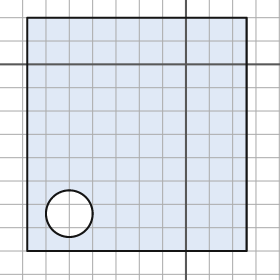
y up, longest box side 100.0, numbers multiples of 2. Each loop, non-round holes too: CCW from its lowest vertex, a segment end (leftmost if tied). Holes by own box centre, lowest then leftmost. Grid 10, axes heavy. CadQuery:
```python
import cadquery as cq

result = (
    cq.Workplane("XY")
    .moveTo(-68.0, -80.0)
    .lineTo(26.0, -80.0)
    .lineTo(26.0, 20.0)
    .lineTo(-68.0, 20.0)
    .close()
    .moveTo(-50.0, -64.0)
    .circle(10.0)
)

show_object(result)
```